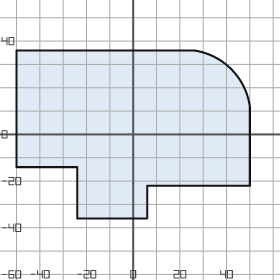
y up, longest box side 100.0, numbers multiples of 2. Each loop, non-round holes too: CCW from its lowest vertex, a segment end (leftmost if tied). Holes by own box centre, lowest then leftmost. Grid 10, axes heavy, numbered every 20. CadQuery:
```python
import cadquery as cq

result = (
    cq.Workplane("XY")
    .moveTo(-24.0, -36.0)
    .lineTo(6.0, -36.0)
    .lineTo(6.0, -22.0)
    .lineTo(50.0, -22.0)
    .lineTo(50.0, 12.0)
    .threePointArc((42.0, 28.0), (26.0, 36.0))
    .lineTo(-50.0, 36.0)
    .lineTo(-50.0, -14.0)
    .lineTo(-24.0, -14.0)
    .close()
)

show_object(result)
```